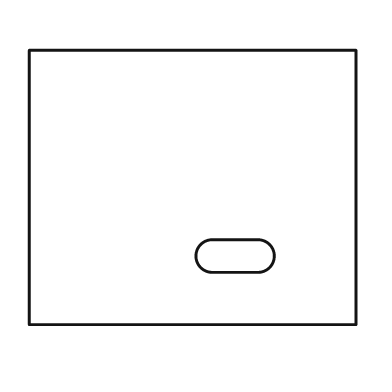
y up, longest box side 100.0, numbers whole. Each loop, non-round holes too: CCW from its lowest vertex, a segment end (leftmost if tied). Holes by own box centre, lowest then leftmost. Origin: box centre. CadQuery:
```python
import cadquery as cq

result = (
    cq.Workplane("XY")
    .moveTo(-50.0, -42.0)
    .lineTo(50.0, -42.0)
    .lineTo(50.0, 42.0)
    .lineTo(-50.0, 42.0)
    .close()
    .moveTo(6.0, -26.0)
    .lineTo(20.0, -26.0)
    .threePointArc((25.0, -21.0), (20.0, -16.0))
    .lineTo(6.0, -16.0)
    .threePointArc((1.0, -21.0), (6.0, -26.0))
    .close()
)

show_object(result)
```